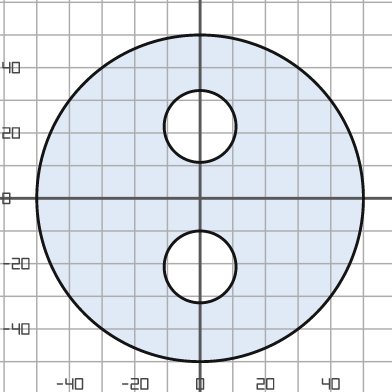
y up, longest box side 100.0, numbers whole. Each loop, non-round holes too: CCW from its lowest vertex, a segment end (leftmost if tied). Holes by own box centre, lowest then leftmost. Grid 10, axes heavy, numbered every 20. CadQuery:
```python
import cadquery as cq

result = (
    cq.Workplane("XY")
    .moveTo(0.0, 0.0)
    .circle(50.0)
    .moveTo(0.0, -21.0)
    .circle(11.0)
    .moveTo(0.0, 22.0)
    .circle(11.0)
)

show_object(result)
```